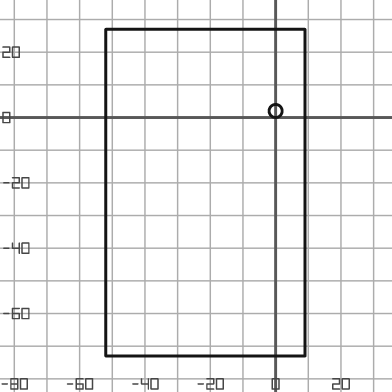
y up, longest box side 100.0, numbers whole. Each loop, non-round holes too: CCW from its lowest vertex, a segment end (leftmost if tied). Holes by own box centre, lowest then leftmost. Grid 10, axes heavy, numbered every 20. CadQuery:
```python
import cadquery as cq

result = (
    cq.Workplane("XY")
    .moveTo(-52.0, -73.0)
    .lineTo(9.0, -73.0)
    .lineTo(9.0, 27.0)
    .lineTo(-52.0, 27.0)
    .close()
    .moveTo(0.0, 2.0)
    .circle(2.0)
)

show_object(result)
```